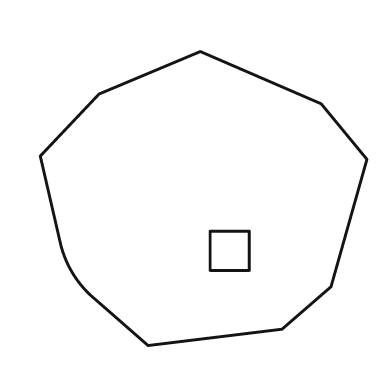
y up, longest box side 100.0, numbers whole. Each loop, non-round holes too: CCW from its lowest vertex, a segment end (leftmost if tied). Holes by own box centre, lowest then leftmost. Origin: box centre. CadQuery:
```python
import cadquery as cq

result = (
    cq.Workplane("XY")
    .moveTo(-17.0, -45.0)
    .lineTo(24.0, -40.0)
    .lineTo(39.0, -27.0)
    .lineTo(50.0, 12.0)
    .lineTo(36.0, 29.0)
    .lineTo(-1.0, 45.0)
    .lineTo(-32.0, 32.0)
    .lineTo(-50.0, 13.0)
    .lineTo(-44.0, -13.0)
    .threePointArc((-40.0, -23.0), (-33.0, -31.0))
    .close()
    .moveTo(2.0, -22.0)
    .lineTo(14.0, -22.0)
    .lineTo(14.0, -10.0)
    .lineTo(2.0, -10.0)
    .close()
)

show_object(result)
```